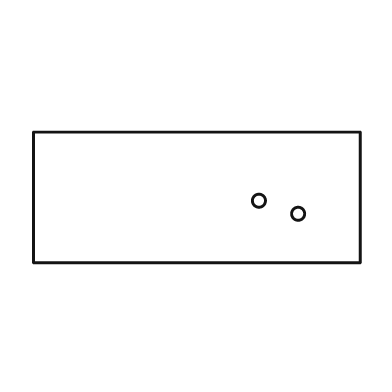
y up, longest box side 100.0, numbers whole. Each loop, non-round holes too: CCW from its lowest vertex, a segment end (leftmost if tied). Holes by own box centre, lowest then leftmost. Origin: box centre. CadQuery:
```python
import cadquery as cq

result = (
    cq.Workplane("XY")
    .moveTo(-50.0, -20.0)
    .lineTo(50.0, -20.0)
    .lineTo(50.0, 20.0)
    .lineTo(-50.0, 20.0)
    .close()
    .moveTo(31.0, -5.0)
    .circle(2.0)
    .moveTo(19.0, -1.0)
    .circle(2.0)
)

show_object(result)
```